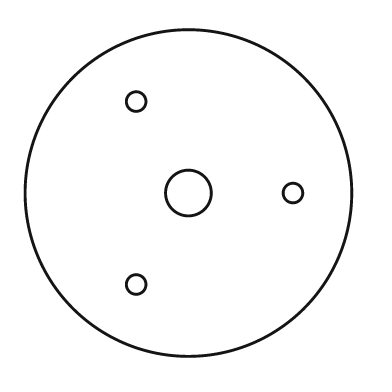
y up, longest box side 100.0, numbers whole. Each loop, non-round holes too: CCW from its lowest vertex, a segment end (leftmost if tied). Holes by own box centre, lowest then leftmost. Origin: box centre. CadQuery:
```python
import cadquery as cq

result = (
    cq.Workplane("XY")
    .moveTo(0.0, 0.0)
    .circle(50.0)
    .moveTo(-16.0, -28.0)
    .circle(3.0)
    .moveTo(0.0, 0.0)
    .circle(7.0)
    .moveTo(32.0, 0.0)
    .circle(3.0)
    .moveTo(-16.0, 28.0)
    .circle(3.0)
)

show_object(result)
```